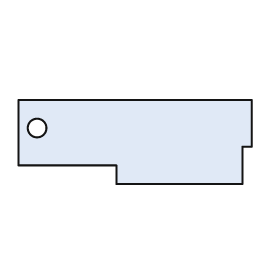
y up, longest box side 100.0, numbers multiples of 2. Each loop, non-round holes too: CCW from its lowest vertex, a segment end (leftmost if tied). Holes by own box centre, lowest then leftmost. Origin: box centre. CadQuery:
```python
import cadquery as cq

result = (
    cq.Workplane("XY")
    .moveTo(-8.0, -18.0)
    .lineTo(46.0, -18.0)
    .lineTo(46.0, -2.0)
    .lineTo(50.0, -2.0)
    .lineTo(50.0, 18.0)
    .lineTo(-50.0, 18.0)
    .lineTo(-50.0, -10.0)
    .lineTo(-8.0, -10.0)
    .close()
    .moveTo(-42.0, 6.0)
    .circle(4.0)
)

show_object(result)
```